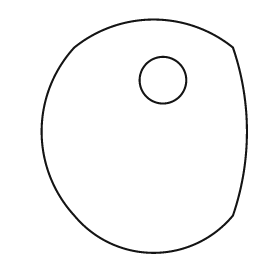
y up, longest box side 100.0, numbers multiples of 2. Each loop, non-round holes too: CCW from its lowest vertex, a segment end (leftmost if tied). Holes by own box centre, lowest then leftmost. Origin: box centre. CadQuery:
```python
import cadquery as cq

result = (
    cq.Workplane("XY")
    .moveTo(-30.0, -34.0)
    .threePointArc((4.0, -50.0), (38.0, -34.0))
    .threePointArc((44.0, 2.0), (38.0, 38.0))
    .threePointArc((4.0, 50.0), (-30.0, 38.0))
    .threePointArc((-44.0, 2.0), (-30.0, -34.0))
    .close()
    .moveTo(8.0, 24.0)
    .circle(10.0)
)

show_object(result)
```